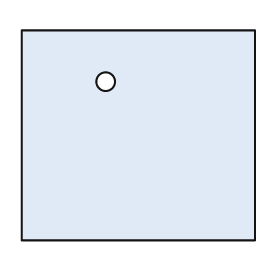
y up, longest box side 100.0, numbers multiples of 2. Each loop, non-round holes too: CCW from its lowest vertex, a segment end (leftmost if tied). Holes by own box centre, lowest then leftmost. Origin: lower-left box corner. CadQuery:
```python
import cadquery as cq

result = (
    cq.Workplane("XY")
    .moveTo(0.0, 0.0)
    .lineTo(100.0, 0.0)
    .lineTo(100.0, 90.0)
    .lineTo(0.0, 90.0)
    .close()
    .moveTo(36.0, 68.0)
    .circle(4.0)
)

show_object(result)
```